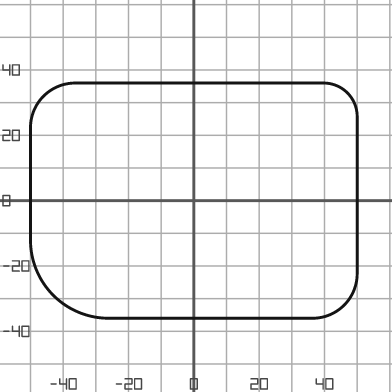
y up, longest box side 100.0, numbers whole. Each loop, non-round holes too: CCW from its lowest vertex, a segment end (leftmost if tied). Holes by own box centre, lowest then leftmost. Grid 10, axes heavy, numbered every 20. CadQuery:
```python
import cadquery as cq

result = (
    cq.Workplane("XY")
    .moveTo(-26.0, -36.0)
    .lineTo(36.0, -36.0)
    .threePointArc((46.0, -32.0), (50.0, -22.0))
    .lineTo(50.0, 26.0)
    .threePointArc((47.0, 33.0), (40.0, 36.0))
    .lineTo(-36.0, 36.0)
    .threePointArc((-46.0, 32.0), (-50.0, 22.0))
    .lineTo(-50.0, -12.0)
    .threePointArc((-43.0, -29.0), (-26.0, -36.0))
    .close()
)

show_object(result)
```